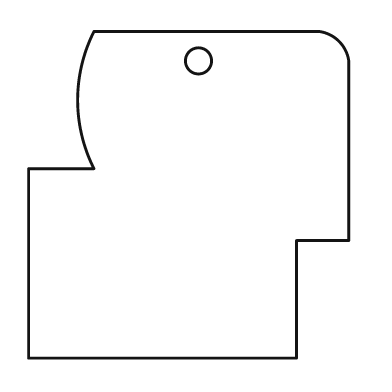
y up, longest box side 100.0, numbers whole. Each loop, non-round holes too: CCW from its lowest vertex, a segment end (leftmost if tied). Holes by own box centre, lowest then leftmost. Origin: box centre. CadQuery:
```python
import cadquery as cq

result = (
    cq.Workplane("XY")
    .moveTo(-49.0, -50.0)
    .lineTo(33.0, -50.0)
    .lineTo(33.0, -14.0)
    .lineTo(49.0, -14.0)
    .lineTo(49.0, 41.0)
    .threePointArc((46.0, 47.0), (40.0, 50.0))
    .lineTo(-29.0, 50.0)
    .threePointArc((-34.0, 29.0), (-29.0, 8.0))
    .lineTo(-49.0, 8.0)
    .close()
    .moveTo(3.0, 41.0)
    .circle(4.0)
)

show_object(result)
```